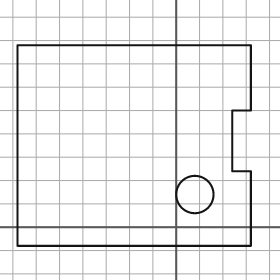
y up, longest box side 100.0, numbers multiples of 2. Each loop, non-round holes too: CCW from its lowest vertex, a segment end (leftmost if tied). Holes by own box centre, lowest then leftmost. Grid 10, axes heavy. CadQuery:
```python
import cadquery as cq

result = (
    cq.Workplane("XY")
    .moveTo(-68.0, -8.0)
    .lineTo(32.0, -8.0)
    .lineTo(32.0, 24.0)
    .lineTo(24.0, 24.0)
    .lineTo(24.0, 50.0)
    .lineTo(32.0, 50.0)
    .lineTo(32.0, 78.0)
    .lineTo(-68.0, 78.0)
    .close()
    .moveTo(8.0, 14.0)
    .circle(8.0)
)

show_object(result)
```